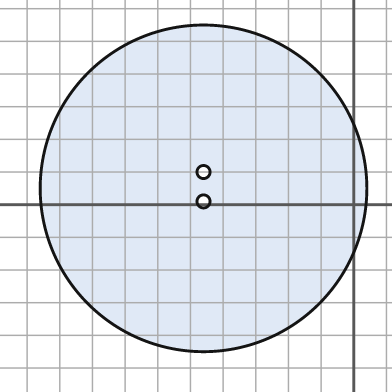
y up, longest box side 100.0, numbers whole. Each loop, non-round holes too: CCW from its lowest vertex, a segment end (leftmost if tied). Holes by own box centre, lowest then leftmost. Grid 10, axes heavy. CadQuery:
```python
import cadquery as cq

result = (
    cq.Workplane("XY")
    .moveTo(-46.0, 5.0)
    .circle(50.0)
    .moveTo(-46.0, 1.0)
    .circle(2.0)
    .moveTo(-46.0, 10.0)
    .circle(2.0)
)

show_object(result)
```